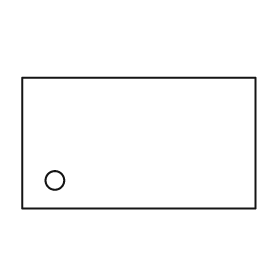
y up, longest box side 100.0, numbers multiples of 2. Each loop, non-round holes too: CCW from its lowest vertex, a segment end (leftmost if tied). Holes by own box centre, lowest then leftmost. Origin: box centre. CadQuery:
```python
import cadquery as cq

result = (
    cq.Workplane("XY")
    .moveTo(-50.0, -28.0)
    .lineTo(50.0, -28.0)
    .lineTo(50.0, 28.0)
    .lineTo(-50.0, 28.0)
    .close()
    .moveTo(-36.0, -16.0)
    .circle(4.0)
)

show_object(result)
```